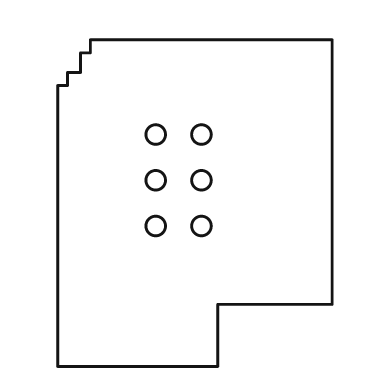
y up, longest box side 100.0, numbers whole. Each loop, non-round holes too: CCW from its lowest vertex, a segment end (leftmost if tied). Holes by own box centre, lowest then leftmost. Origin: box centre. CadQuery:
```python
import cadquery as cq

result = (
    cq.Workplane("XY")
    .moveTo(-42.0, -50.0)
    .lineTo(7.0, -50.0)
    .lineTo(7.0, -31.0)
    .lineTo(42.0, -31.0)
    .lineTo(42.0, 50.0)
    .lineTo(-32.0, 50.0)
    .lineTo(-32.0, 46.0)
    .lineTo(-35.0, 46.0)
    .lineTo(-35.0, 40.0)
    .lineTo(-39.0, 40.0)
    .lineTo(-39.0, 36.0)
    .lineTo(-42.0, 36.0)
    .close()
    .moveTo(-12.0, -7.0)
    .circle(3.0)
    .moveTo(2.0, -7.0)
    .circle(3.0)
    .moveTo(-12.0, 7.0)
    .circle(3.0)
    .moveTo(2.0, 7.0)
    .circle(3.0)
    .moveTo(-12.0, 21.0)
    .circle(3.0)
    .moveTo(2.0, 21.0)
    .circle(3.0)
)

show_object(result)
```